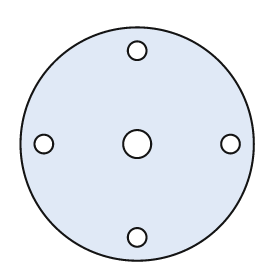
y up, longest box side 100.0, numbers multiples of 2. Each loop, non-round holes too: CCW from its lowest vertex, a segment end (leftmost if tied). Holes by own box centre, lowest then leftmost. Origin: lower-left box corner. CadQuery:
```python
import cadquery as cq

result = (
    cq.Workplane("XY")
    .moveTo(50.0, 50.0)
    .circle(50.0)
    .moveTo(50.0, 10.0)
    .circle(4.0)
    .moveTo(10.0, 50.0)
    .circle(4.0)
    .moveTo(50.0, 50.0)
    .circle(6.0)
    .moveTo(90.0, 50.0)
    .circle(4.0)
    .moveTo(50.0, 90.0)
    .circle(4.0)
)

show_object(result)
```